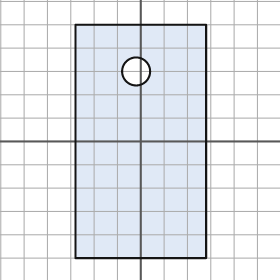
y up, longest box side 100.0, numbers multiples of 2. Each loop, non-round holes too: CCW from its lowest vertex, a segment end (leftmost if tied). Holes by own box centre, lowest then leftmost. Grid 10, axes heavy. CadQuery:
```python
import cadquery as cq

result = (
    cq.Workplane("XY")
    .moveTo(-28.0, -50.0)
    .lineTo(28.0, -50.0)
    .lineTo(28.0, 50.0)
    .lineTo(-28.0, 50.0)
    .close()
    .moveTo(-2.0, 30.0)
    .circle(6.0)
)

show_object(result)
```